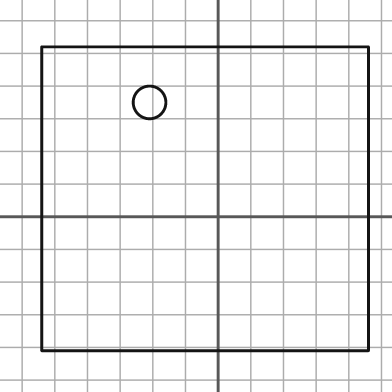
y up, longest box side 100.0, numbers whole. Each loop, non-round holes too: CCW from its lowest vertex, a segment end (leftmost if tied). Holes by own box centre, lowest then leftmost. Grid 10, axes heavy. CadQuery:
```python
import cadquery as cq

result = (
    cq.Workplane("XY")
    .moveTo(-54.0, -41.0)
    .lineTo(46.0, -41.0)
    .lineTo(46.0, 52.0)
    .lineTo(-54.0, 52.0)
    .close()
    .moveTo(-21.0, 35.0)
    .circle(5.0)
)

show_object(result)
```